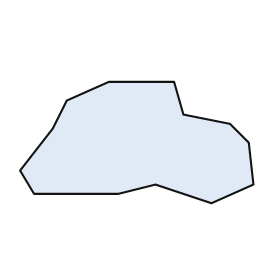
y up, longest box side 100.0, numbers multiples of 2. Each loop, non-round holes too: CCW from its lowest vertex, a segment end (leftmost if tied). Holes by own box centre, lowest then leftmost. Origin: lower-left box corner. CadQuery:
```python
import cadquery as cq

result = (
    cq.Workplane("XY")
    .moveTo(82.0, 0.0)
    .lineTo(100.0, 8.0)
    .lineTo(98.0, 26.0)
    .lineTo(90.0, 34.0)
    .lineTo(70.0, 38.0)
    .lineTo(66.0, 52.0)
    .lineTo(38.0, 52.0)
    .lineTo(20.0, 44.0)
    .lineTo(14.0, 32.0)
    .lineTo(0.0, 14.0)
    .lineTo(6.0, 4.0)
    .lineTo(42.0, 4.0)
    .lineTo(58.0, 8.0)
    .close()
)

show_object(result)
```